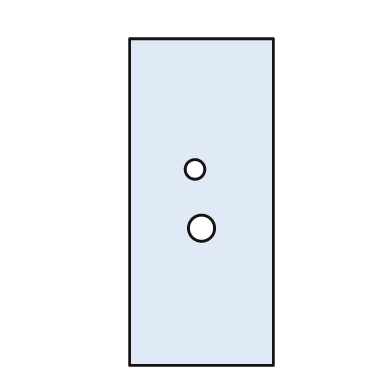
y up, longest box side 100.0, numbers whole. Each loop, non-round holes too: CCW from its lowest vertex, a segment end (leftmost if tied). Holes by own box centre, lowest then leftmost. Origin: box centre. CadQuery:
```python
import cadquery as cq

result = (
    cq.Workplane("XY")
    .moveTo(-22.0, -50.0)
    .lineTo(22.0, -50.0)
    .lineTo(22.0, 50.0)
    .lineTo(-22.0, 50.0)
    .close()
    .moveTo(0.0, -8.0)
    .circle(4.0)
    .moveTo(-2.0, 10.0)
    .circle(3.0)
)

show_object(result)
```